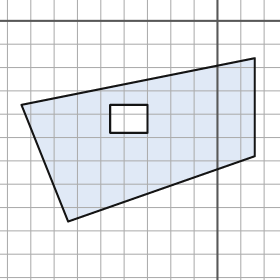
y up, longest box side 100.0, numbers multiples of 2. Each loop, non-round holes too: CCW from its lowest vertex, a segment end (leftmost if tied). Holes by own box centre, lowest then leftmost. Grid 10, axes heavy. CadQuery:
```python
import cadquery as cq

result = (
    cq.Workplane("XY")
    .moveTo(-64.0, -86.0)
    .lineTo(16.0, -58.0)
    .lineTo(16.0, -16.0)
    .lineTo(-84.0, -36.0)
    .close()
    .moveTo(-46.0, -48.0)
    .lineTo(-30.0, -48.0)
    .lineTo(-30.0, -36.0)
    .lineTo(-46.0, -36.0)
    .close()
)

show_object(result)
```